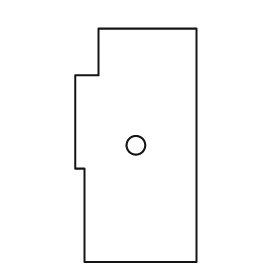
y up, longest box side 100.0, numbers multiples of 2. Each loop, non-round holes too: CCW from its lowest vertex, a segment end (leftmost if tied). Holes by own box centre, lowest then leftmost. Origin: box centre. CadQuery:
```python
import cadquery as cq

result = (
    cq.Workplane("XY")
    .moveTo(-22.0, -50.0)
    .lineTo(26.0, -50.0)
    .lineTo(26.0, 50.0)
    .lineTo(-16.0, 50.0)
    .lineTo(-16.0, 30.0)
    .lineTo(-26.0, 30.0)
    .lineTo(-26.0, -10.0)
    .lineTo(-22.0, -10.0)
    .close()
    .moveTo(0.0, 0.0)
    .circle(4.0)
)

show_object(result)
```